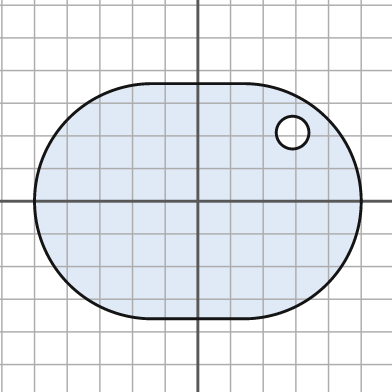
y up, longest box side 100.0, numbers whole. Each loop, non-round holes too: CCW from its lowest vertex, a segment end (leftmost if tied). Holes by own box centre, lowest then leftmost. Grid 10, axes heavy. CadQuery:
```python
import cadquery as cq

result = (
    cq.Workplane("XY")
    .moveTo(-14.0, -36.0)
    .lineTo(14.0, -36.0)
    .threePointArc((50.0, 0.0), (14.0, 36.0))
    .lineTo(-14.0, 36.0)
    .threePointArc((-50.0, 0.0), (-14.0, -36.0))
    .close()
    .moveTo(29.0, 21.0)
    .circle(5.0)
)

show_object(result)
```